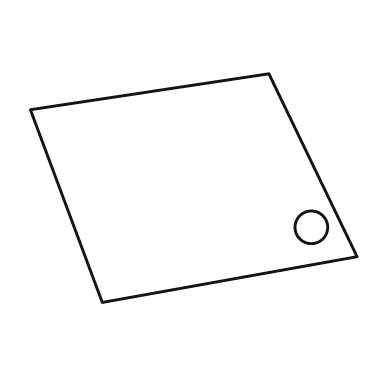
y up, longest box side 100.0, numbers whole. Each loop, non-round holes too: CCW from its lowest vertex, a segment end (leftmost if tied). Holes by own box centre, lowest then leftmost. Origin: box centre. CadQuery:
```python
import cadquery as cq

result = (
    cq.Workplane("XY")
    .moveTo(-28.0, -35.0)
    .lineTo(50.0, -21.0)
    .lineTo(23.0, 35.0)
    .lineTo(-50.0, 24.0)
    .close()
    .moveTo(36.0, -12.0)
    .circle(5.0)
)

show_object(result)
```